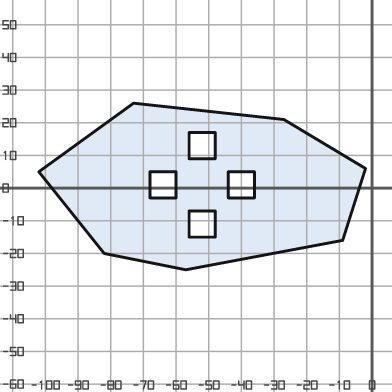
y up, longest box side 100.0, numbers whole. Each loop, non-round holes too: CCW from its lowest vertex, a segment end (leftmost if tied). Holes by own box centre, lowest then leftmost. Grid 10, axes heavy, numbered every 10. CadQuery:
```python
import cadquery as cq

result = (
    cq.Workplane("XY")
    .moveTo(-57.0, -25.0)
    .lineTo(-9.0, -16.0)
    .lineTo(-2.0, 6.0)
    .lineTo(-27.0, 21.0)
    .lineTo(-73.0, 26.0)
    .lineTo(-102.0, 5.0)
    .lineTo(-82.0, -20.0)
    .close()
    .moveTo(-56.0, -15.0)
    .lineTo(-48.0, -15.0)
    .lineTo(-48.0, -7.0)
    .lineTo(-56.0, -7.0)
    .close()
    .moveTo(-68.0, -3.0)
    .lineTo(-60.0, -3.0)
    .lineTo(-60.0, 5.0)
    .lineTo(-68.0, 5.0)
    .close()
    .moveTo(-44.0, -3.0)
    .lineTo(-36.0, -3.0)
    .lineTo(-36.0, 5.0)
    .lineTo(-44.0, 5.0)
    .close()
    .moveTo(-56.0, 9.0)
    .lineTo(-48.0, 9.0)
    .lineTo(-48.0, 17.0)
    .lineTo(-56.0, 17.0)
    .close()
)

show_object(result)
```